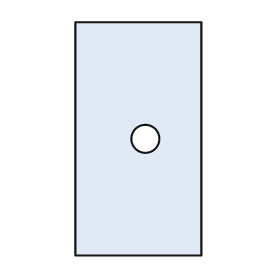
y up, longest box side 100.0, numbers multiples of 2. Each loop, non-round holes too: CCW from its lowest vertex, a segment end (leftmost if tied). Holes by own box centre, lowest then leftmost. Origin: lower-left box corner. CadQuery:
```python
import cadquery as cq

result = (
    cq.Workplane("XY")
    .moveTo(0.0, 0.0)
    .lineTo(54.0, 0.0)
    .lineTo(54.0, 100.0)
    .lineTo(0.0, 100.0)
    .close()
    .moveTo(30.0, 50.0)
    .circle(6.0)
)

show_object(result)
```